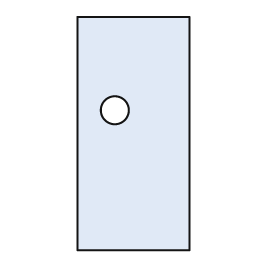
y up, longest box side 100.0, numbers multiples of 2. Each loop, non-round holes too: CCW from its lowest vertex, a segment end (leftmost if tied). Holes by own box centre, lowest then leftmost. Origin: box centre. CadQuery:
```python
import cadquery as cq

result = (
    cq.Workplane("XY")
    .moveTo(-24.0, -50.0)
    .lineTo(24.0, -50.0)
    .lineTo(24.0, 50.0)
    .lineTo(-24.0, 50.0)
    .close()
    .moveTo(-8.0, 10.0)
    .circle(6.0)
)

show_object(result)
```